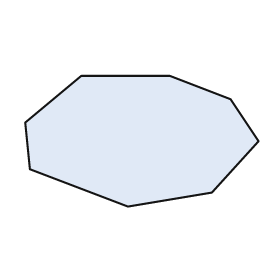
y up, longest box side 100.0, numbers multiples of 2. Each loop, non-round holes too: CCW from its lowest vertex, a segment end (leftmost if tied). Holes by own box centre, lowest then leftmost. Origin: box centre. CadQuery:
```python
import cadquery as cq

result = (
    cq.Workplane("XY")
    .moveTo(-6.0, -28.0)
    .lineTo(30.0, -22.0)
    .lineTo(50.0, 0.0)
    .lineTo(38.0, 18.0)
    .lineTo(12.0, 28.0)
    .lineTo(-26.0, 28.0)
    .lineTo(-50.0, 8.0)
    .lineTo(-48.0, -12.0)
    .close()
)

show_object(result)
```